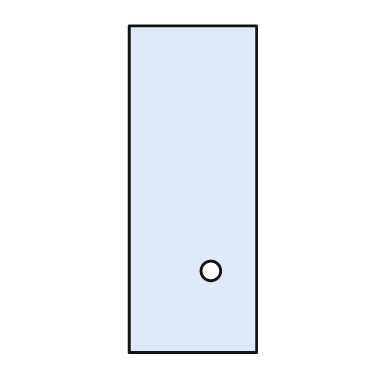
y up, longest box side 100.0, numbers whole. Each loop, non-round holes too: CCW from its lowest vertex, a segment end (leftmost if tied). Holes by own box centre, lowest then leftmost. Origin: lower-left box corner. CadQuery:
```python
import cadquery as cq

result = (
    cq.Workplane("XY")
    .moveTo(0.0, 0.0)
    .lineTo(39.0, 0.0)
    .lineTo(39.0, 100.0)
    .lineTo(0.0, 100.0)
    .close()
    .moveTo(25.0, 25.0)
    .circle(3.0)
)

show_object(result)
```